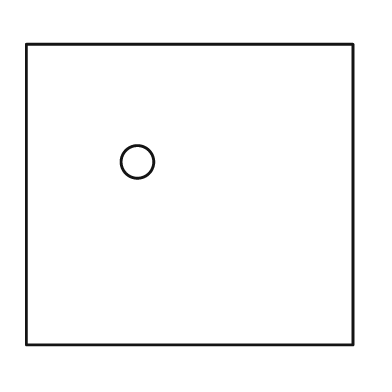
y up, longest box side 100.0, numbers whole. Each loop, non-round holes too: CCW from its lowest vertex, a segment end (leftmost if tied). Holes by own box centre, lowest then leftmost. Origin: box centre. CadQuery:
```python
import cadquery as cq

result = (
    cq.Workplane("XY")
    .moveTo(-50.0, -46.0)
    .lineTo(50.0, -46.0)
    .lineTo(50.0, 46.0)
    .lineTo(-50.0, 46.0)
    .close()
    .moveTo(-16.0, 10.0)
    .circle(5.0)
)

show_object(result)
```